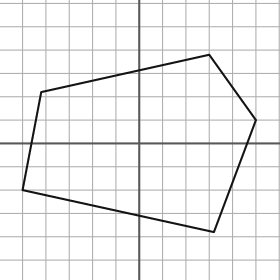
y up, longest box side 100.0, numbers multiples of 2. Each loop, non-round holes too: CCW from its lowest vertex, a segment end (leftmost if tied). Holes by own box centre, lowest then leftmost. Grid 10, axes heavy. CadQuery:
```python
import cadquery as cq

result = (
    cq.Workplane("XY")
    .moveTo(32.0, -38.0)
    .lineTo(50.0, 10.0)
    .lineTo(30.0, 38.0)
    .lineTo(-42.0, 22.0)
    .lineTo(-50.0, -20.0)
    .close()
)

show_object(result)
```